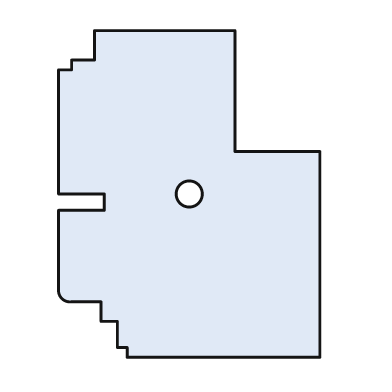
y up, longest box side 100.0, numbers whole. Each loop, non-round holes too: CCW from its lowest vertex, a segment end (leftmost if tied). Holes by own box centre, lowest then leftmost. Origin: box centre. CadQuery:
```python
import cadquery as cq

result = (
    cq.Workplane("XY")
    .moveTo(-19.0, -50.0)
    .lineTo(40.0, -50.0)
    .lineTo(40.0, 13.0)
    .lineTo(14.0, 13.0)
    .lineTo(14.0, 50.0)
    .lineTo(-29.0, 50.0)
    .lineTo(-29.0, 41.0)
    .lineTo(-36.0, 41.0)
    .lineTo(-36.0, 38.0)
    .lineTo(-40.0, 38.0)
    .lineTo(-40.0, 0.0)
    .lineTo(-26.0, 0.0)
    .lineTo(-26.0, -5.0)
    .lineTo(-40.0, -5.0)
    .lineTo(-40.0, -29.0)
    .threePointArc((-39.0, -32.0), (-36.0, -33.0))
    .lineTo(-27.0, -33.0)
    .lineTo(-27.0, -39.0)
    .lineTo(-22.0, -39.0)
    .lineTo(-22.0, -47.0)
    .lineTo(-19.0, -47.0)
    .close()
    .moveTo(0.0, 0.0)
    .circle(4.0)
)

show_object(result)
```